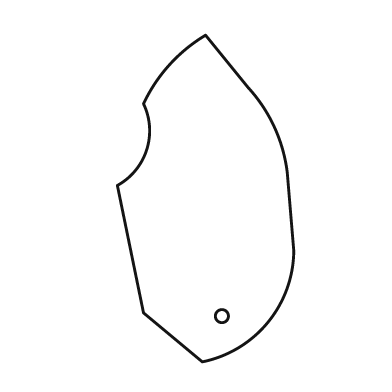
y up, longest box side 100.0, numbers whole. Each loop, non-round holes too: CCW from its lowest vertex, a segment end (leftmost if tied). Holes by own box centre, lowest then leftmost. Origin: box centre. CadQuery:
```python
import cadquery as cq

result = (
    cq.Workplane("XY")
    .moveTo(-1.0, -50.0)
    .threePointArc((19.0, -38.0), (27.0, -16.0))
    .lineTo(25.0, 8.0)
    .threePointArc((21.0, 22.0), (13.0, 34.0))
    .lineTo(0.0, 50.0)
    .threePointArc((-11.0, 41.0), (-19.0, 29.0))
    .threePointArc((-18.0, 15.0), (-27.0, 4.0))
    .lineTo(-19.0, -35.0)
    .close()
    .moveTo(5.0, -36.0)
    .circle(2.0)
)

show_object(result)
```